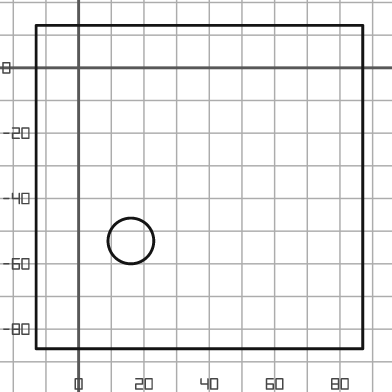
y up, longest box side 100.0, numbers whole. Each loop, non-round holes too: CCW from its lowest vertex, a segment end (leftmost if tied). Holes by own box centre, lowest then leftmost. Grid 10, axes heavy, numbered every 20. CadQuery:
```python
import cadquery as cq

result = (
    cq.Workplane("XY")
    .moveTo(-13.0, -86.0)
    .lineTo(87.0, -86.0)
    .lineTo(87.0, 13.0)
    .lineTo(-13.0, 13.0)
    .close()
    .moveTo(16.0, -53.0)
    .circle(7.0)
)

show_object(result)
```